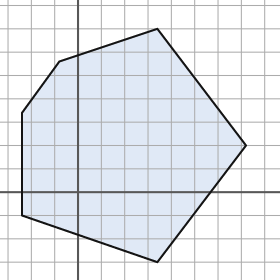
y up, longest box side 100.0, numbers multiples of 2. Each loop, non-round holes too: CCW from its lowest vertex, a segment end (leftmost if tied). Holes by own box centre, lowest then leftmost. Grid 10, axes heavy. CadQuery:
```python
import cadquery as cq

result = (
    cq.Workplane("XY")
    .moveTo(34.0, -30.0)
    .lineTo(72.0, 20.0)
    .lineTo(34.0, 70.0)
    .lineTo(-8.0, 56.0)
    .lineTo(-24.0, 34.0)
    .lineTo(-24.0, -10.0)
    .close()
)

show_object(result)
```